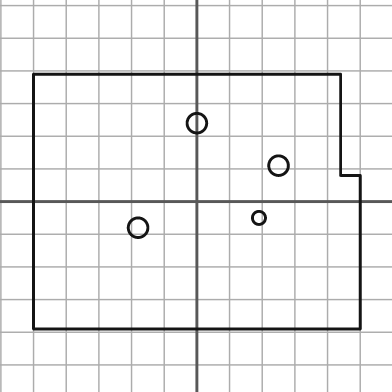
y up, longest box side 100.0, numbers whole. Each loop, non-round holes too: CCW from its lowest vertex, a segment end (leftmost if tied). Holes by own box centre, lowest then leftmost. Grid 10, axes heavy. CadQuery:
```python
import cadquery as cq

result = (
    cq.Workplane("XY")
    .moveTo(-50.0, -39.0)
    .lineTo(50.0, -39.0)
    .lineTo(50.0, 8.0)
    .lineTo(44.0, 8.0)
    .lineTo(44.0, 39.0)
    .lineTo(-50.0, 39.0)
    .close()
    .moveTo(-18.0, -8.0)
    .circle(3.0)
    .moveTo(19.0, -5.0)
    .circle(2.0)
    .moveTo(25.0, 11.0)
    .circle(3.0)
    .moveTo(0.0, 24.0)
    .circle(3.0)
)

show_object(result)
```